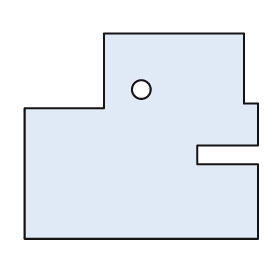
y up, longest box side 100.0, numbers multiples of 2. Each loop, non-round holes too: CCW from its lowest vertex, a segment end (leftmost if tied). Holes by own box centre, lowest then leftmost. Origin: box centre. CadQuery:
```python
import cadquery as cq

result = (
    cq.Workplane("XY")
    .moveTo(-50.0, -44.0)
    .lineTo(50.0, -44.0)
    .lineTo(50.0, -12.0)
    .lineTo(24.0, -12.0)
    .lineTo(24.0, -4.0)
    .lineTo(50.0, -4.0)
    .lineTo(50.0, 14.0)
    .lineTo(44.0, 14.0)
    .lineTo(44.0, 44.0)
    .lineTo(-16.0, 44.0)
    .lineTo(-16.0, 12.0)
    .lineTo(-50.0, 12.0)
    .close()
    .moveTo(0.0, 20.0)
    .circle(4.0)
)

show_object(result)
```